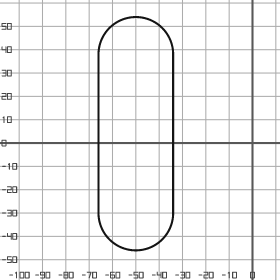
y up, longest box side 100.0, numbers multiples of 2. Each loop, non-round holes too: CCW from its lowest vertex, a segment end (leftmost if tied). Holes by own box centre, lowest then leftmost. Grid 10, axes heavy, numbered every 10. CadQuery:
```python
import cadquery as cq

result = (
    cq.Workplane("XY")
    .moveTo(-66.0, -30.0)
    .threePointArc((-50.0, -46.0), (-34.0, -30.0))
    .lineTo(-34.0, 38.0)
    .threePointArc((-50.0, 54.0), (-66.0, 38.0))
    .close()
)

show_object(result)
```